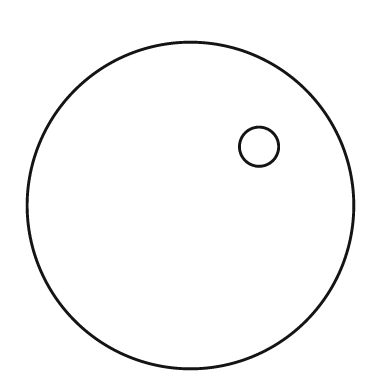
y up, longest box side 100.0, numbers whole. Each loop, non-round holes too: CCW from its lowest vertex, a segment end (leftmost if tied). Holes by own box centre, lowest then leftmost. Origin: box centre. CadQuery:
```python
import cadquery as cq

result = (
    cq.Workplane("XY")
    .moveTo(0.0, 0.0)
    .circle(50.0)
    .moveTo(21.0, 18.0)
    .circle(6.0)
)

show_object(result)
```